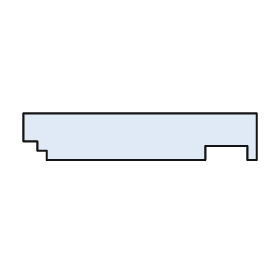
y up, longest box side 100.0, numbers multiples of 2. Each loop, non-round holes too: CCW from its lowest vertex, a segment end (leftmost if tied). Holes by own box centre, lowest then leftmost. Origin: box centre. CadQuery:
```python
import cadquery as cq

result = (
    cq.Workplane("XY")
    .moveTo(-40.0, -10.0)
    .lineTo(28.0, -10.0)
    .lineTo(28.0, -4.0)
    .lineTo(46.0, -4.0)
    .lineTo(46.0, -10.0)
    .lineTo(50.0, -10.0)
    .lineTo(50.0, 10.0)
    .lineTo(-50.0, 10.0)
    .lineTo(-50.0, -2.0)
    .lineTo(-44.0, -2.0)
    .lineTo(-44.0, -6.0)
    .lineTo(-40.0, -6.0)
    .close()
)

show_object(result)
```